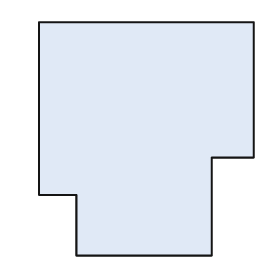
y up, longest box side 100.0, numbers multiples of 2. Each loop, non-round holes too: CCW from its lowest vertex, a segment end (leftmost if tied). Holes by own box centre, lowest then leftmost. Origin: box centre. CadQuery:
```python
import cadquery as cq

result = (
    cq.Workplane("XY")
    .moveTo(-30.0, -50.0)
    .lineTo(28.0, -50.0)
    .lineTo(28.0, -8.0)
    .lineTo(46.0, -8.0)
    .lineTo(46.0, 50.0)
    .lineTo(-46.0, 50.0)
    .lineTo(-46.0, -24.0)
    .lineTo(-30.0, -24.0)
    .close()
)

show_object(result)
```